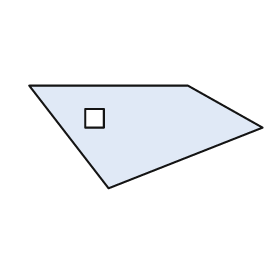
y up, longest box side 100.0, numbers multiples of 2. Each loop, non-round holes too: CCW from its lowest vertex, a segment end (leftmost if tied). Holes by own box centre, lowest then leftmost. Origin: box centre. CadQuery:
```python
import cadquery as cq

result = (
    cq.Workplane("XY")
    .moveTo(-16.0, -22.0)
    .lineTo(50.0, 4.0)
    .lineTo(18.0, 22.0)
    .lineTo(-50.0, 22.0)
    .close()
    .moveTo(-26.0, 4.0)
    .lineTo(-18.0, 4.0)
    .lineTo(-18.0, 12.0)
    .lineTo(-26.0, 12.0)
    .close()
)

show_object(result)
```